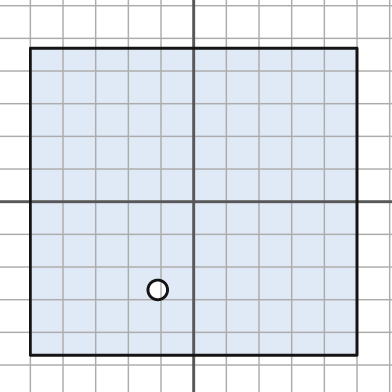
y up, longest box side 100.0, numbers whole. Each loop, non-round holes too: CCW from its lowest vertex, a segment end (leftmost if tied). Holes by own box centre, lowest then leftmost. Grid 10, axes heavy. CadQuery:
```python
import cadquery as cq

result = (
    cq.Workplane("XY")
    .moveTo(-50.0, -47.0)
    .lineTo(50.0, -47.0)
    .lineTo(50.0, 47.0)
    .lineTo(-50.0, 47.0)
    .close()
    .moveTo(-11.0, -27.0)
    .circle(3.0)
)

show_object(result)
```